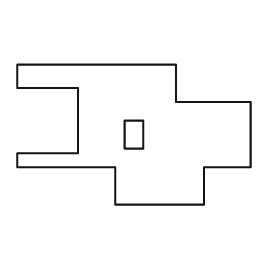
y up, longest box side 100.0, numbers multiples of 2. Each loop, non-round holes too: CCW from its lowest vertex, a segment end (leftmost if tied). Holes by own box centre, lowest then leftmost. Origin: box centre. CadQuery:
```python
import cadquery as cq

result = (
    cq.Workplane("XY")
    .moveTo(-8.0, -30.0)
    .lineTo(30.0, -30.0)
    .lineTo(30.0, -14.0)
    .lineTo(50.0, -14.0)
    .lineTo(50.0, 14.0)
    .lineTo(18.0, 14.0)
    .lineTo(18.0, 30.0)
    .lineTo(-50.0, 30.0)
    .lineTo(-50.0, 20.0)
    .lineTo(-24.0, 20.0)
    .lineTo(-24.0, -8.0)
    .lineTo(-50.0, -8.0)
    .lineTo(-50.0, -14.0)
    .lineTo(-8.0, -14.0)
    .close()
    .moveTo(-4.0, -6.0)
    .lineTo(4.0, -6.0)
    .lineTo(4.0, 6.0)
    .lineTo(-4.0, 6.0)
    .close()
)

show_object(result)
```